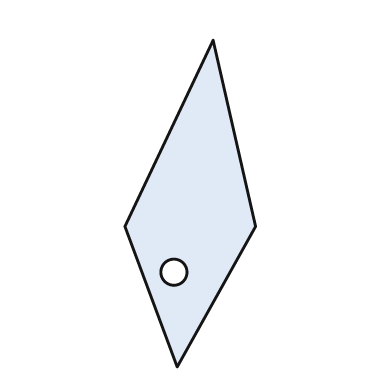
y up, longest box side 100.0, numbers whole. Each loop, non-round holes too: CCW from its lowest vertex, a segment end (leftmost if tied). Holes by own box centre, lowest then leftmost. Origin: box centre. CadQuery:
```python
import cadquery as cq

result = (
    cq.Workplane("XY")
    .moveTo(-4.0, -50.0)
    .lineTo(20.0, -7.0)
    .lineTo(7.0, 50.0)
    .lineTo(-20.0, -7.0)
    .close()
    .moveTo(-5.0, -21.0)
    .circle(4.0)
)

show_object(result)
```